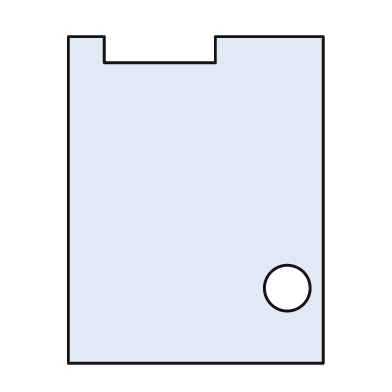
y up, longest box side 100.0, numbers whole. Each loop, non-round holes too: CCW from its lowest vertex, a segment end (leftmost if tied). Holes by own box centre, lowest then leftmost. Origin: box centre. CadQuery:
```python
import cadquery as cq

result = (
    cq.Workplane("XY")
    .moveTo(-39.0, -50.0)
    .lineTo(39.0, -50.0)
    .lineTo(39.0, 50.0)
    .lineTo(6.0, 50.0)
    .lineTo(6.0, 42.0)
    .lineTo(-28.0, 42.0)
    .lineTo(-28.0, 50.0)
    .lineTo(-39.0, 50.0)
    .close()
    .moveTo(28.0, -27.0)
    .circle(7.0)
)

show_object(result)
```